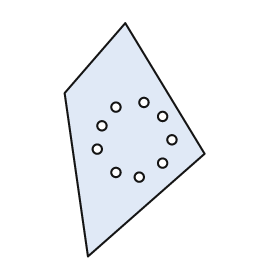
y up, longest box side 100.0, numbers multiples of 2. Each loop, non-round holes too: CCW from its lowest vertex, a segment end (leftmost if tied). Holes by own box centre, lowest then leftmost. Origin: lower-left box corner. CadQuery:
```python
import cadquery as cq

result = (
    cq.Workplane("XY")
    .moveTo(10.0, 0.0)
    .lineTo(60.0, 44.0)
    .lineTo(26.0, 100.0)
    .lineTo(0.0, 70.0)
    .close()
    .moveTo(32.0, 34.0)
    .circle(2.0)
    .moveTo(22.0, 36.0)
    .circle(2.0)
    .moveTo(42.0, 40.0)
    .circle(2.0)
    .moveTo(14.0, 46.0)
    .circle(2.0)
    .moveTo(46.0, 50.0)
    .circle(2.0)
    .moveTo(16.0, 56.0)
    .circle(2.0)
    .moveTo(42.0, 60.0)
    .circle(2.0)
    .moveTo(22.0, 64.0)
    .circle(2.0)
    .moveTo(34.0, 66.0)
    .circle(2.0)
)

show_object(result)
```